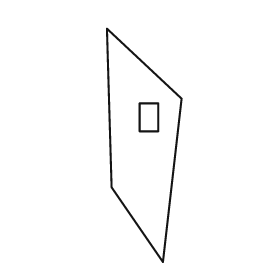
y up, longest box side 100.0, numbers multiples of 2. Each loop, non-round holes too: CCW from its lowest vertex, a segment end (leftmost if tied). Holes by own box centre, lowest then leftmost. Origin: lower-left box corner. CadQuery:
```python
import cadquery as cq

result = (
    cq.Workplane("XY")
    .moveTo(24.0, 0.0)
    .lineTo(32.0, 70.0)
    .lineTo(0.0, 100.0)
    .lineTo(2.0, 32.0)
    .close()
    .moveTo(14.0, 56.0)
    .lineTo(22.0, 56.0)
    .lineTo(22.0, 68.0)
    .lineTo(14.0, 68.0)
    .close()
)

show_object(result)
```